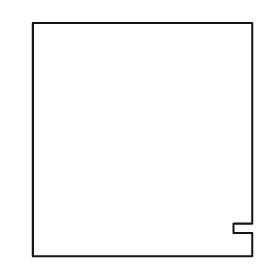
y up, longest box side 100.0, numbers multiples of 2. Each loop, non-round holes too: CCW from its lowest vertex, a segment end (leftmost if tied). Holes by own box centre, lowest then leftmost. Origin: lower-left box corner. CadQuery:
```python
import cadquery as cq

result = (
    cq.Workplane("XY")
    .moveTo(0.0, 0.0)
    .lineTo(94.0, 0.0)
    .lineTo(94.0, 10.0)
    .lineTo(86.0, 10.0)
    .lineTo(86.0, 14.0)
    .lineTo(94.0, 14.0)
    .lineTo(94.0, 100.0)
    .lineTo(0.0, 100.0)
    .close()
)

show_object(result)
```